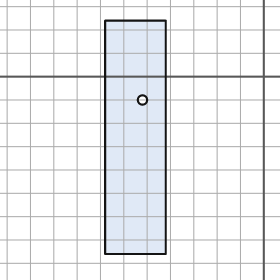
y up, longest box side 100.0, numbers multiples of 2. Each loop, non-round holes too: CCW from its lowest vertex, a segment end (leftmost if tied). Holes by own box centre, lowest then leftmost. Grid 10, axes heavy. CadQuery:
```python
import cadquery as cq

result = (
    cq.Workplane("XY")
    .moveTo(-68.0, -76.0)
    .lineTo(-42.0, -76.0)
    .lineTo(-42.0, 24.0)
    .lineTo(-68.0, 24.0)
    .close()
    .moveTo(-52.0, -10.0)
    .circle(2.0)
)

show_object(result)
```